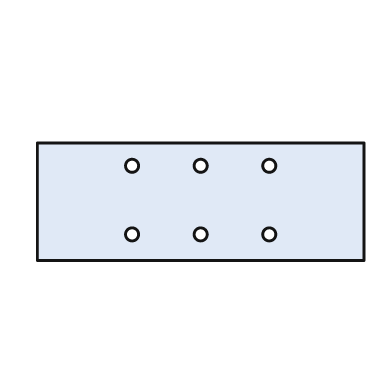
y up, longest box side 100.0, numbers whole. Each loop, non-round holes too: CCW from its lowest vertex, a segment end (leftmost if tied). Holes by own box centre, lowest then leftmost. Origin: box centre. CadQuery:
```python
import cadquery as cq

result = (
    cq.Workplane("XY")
    .moveTo(-50.0, -18.0)
    .lineTo(50.0, -18.0)
    .lineTo(50.0, 18.0)
    .lineTo(-50.0, 18.0)
    .close()
    .moveTo(-21.0, -10.0)
    .circle(2.0)
    .moveTo(0.0, -10.0)
    .circle(2.0)
    .moveTo(21.0, -10.0)
    .circle(2.0)
    .moveTo(-21.0, 11.0)
    .circle(2.0)
    .moveTo(0.0, 11.0)
    .circle(2.0)
    .moveTo(21.0, 11.0)
    .circle(2.0)
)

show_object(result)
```